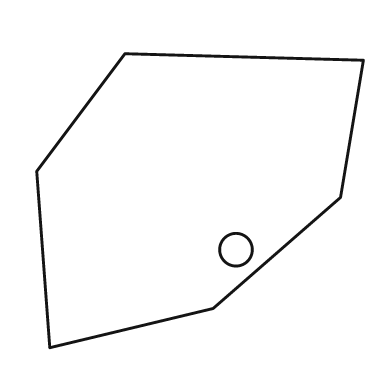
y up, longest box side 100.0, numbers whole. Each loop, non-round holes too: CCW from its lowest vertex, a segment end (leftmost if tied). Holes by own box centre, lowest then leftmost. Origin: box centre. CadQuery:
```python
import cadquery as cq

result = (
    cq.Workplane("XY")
    .moveTo(-46.0, -45.0)
    .lineTo(4.0, -33.0)
    .lineTo(43.0, 1.0)
    .lineTo(50.0, 43.0)
    .lineTo(-23.0, 45.0)
    .lineTo(-50.0, 9.0)
    .close()
    .moveTo(11.0, -15.0)
    .circle(5.0)
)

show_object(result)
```